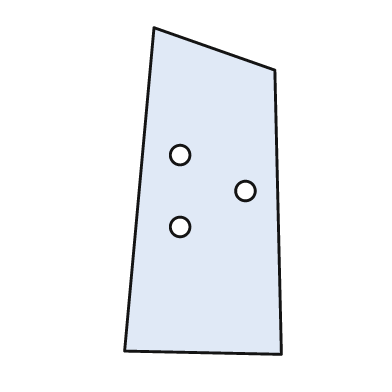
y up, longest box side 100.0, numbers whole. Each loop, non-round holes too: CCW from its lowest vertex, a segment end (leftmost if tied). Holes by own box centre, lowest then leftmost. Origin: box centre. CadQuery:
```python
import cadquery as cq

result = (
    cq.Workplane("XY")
    .moveTo(24.0, -50.0)
    .lineTo(22.0, 37.0)
    .lineTo(-15.0, 50.0)
    .lineTo(-24.0, -49.0)
    .close()
    .moveTo(-7.0, -11.0)
    .circle(3.0)
    .moveTo(13.0, 0.0)
    .circle(3.0)
    .moveTo(-7.0, 11.0)
    .circle(3.0)
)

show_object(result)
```